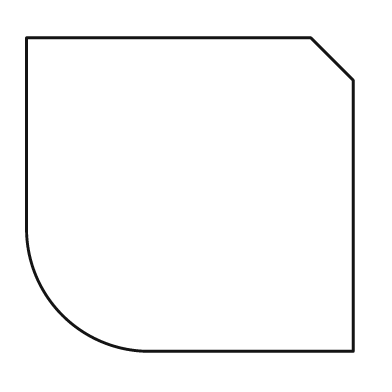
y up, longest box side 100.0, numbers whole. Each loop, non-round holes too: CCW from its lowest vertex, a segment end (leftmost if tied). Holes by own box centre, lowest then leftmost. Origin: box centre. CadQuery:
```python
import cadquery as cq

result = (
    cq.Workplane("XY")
    .moveTo(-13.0, -48.0)
    .lineTo(50.0, -48.0)
    .lineTo(50.0, 35.0)
    .lineTo(37.0, 48.0)
    .lineTo(-50.0, 48.0)
    .lineTo(-50.0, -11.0)
    .threePointArc((-39.0, -37.0), (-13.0, -48.0))
    .close()
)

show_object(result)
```